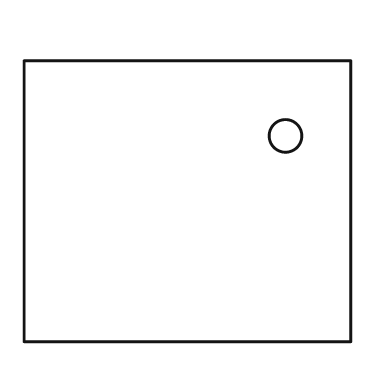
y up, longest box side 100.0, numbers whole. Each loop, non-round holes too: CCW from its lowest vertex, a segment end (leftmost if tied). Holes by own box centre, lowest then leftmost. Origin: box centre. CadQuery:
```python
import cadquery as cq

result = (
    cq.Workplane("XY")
    .moveTo(-50.0, -43.0)
    .lineTo(50.0, -43.0)
    .lineTo(50.0, 43.0)
    .lineTo(-50.0, 43.0)
    .close()
    .moveTo(30.0, 20.0)
    .circle(5.0)
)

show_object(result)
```